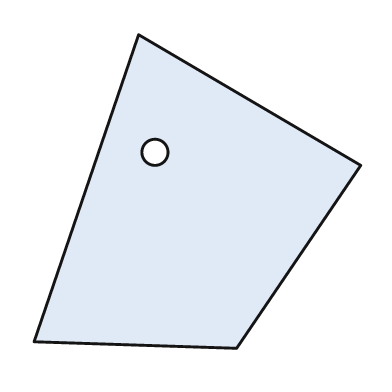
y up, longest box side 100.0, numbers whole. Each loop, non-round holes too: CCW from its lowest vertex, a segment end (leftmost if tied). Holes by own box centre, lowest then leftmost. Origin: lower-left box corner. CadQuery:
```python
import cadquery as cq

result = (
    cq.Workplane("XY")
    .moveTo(62.0, 0.0)
    .lineTo(100.0, 56.0)
    .lineTo(32.0, 96.0)
    .lineTo(0.0, 2.0)
    .close()
    .moveTo(37.0, 60.0)
    .circle(4.0)
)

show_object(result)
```